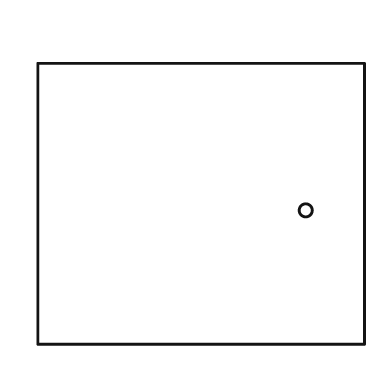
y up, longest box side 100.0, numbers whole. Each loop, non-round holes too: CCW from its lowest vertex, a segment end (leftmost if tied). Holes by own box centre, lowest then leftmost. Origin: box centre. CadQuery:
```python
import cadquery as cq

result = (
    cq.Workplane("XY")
    .moveTo(-50.0, -43.0)
    .lineTo(50.0, -43.0)
    .lineTo(50.0, 43.0)
    .lineTo(-50.0, 43.0)
    .close()
    .moveTo(32.0, -2.0)
    .circle(2.0)
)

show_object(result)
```